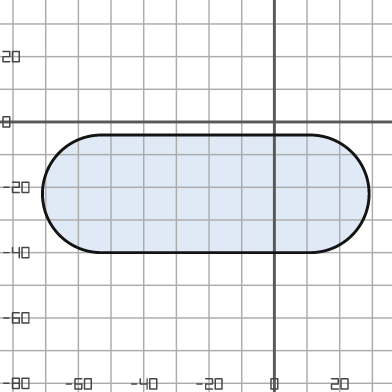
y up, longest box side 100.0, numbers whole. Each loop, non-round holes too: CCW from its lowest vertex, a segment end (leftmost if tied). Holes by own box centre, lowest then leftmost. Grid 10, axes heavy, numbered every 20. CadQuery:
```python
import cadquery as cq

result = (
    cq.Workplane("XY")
    .moveTo(-53.0, -40.0)
    .lineTo(11.0, -40.0)
    .threePointArc((29.0, -22.0), (11.0, -4.0))
    .lineTo(-53.0, -4.0)
    .threePointArc((-71.0, -22.0), (-53.0, -40.0))
    .close()
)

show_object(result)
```